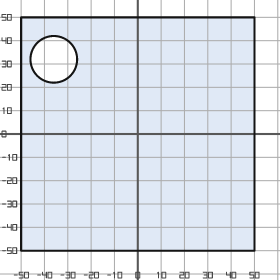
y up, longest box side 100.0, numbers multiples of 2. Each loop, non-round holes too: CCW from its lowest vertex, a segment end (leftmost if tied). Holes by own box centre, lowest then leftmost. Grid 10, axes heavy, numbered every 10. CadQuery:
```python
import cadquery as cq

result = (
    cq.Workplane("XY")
    .moveTo(-50.0, -50.0)
    .lineTo(50.0, -50.0)
    .lineTo(50.0, 50.0)
    .lineTo(-50.0, 50.0)
    .close()
    .moveTo(-36.0, 32.0)
    .circle(10.0)
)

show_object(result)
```